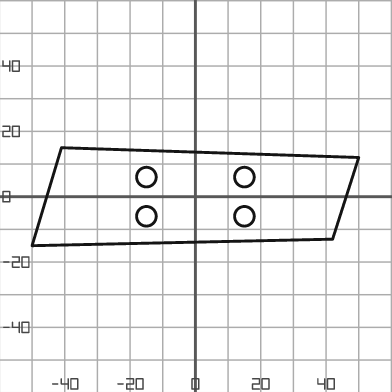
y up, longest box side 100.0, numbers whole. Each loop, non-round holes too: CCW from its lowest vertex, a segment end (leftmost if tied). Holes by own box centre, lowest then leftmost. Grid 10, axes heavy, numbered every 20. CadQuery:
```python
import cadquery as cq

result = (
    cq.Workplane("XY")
    .moveTo(-50.0, -15.0)
    .lineTo(42.0, -13.0)
    .lineTo(50.0, 12.0)
    .lineTo(-41.0, 15.0)
    .close()
    .moveTo(-15.0, -6.0)
    .circle(3.0)
    .moveTo(15.0, -6.0)
    .circle(3.0)
    .moveTo(-15.0, 6.0)
    .circle(3.0)
    .moveTo(15.0, 6.0)
    .circle(3.0)
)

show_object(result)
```